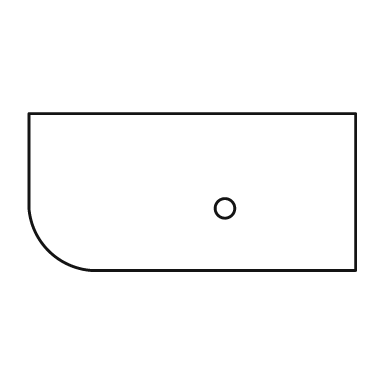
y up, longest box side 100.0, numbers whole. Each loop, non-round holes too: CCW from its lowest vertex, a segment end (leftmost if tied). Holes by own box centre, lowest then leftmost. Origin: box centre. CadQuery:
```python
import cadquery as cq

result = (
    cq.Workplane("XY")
    .moveTo(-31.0, -24.0)
    .lineTo(50.0, -24.0)
    .lineTo(50.0, 24.0)
    .lineTo(-50.0, 24.0)
    .lineTo(-50.0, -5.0)
    .threePointArc((-44.0, -18.0), (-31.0, -24.0))
    .close()
    .moveTo(10.0, -5.0)
    .circle(3.0)
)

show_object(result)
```